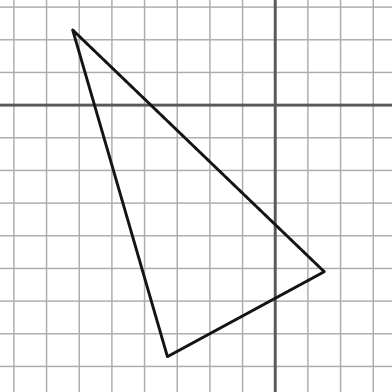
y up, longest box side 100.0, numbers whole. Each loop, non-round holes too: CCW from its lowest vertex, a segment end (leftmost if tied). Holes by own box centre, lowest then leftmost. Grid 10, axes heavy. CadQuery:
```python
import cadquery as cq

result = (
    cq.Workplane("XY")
    .moveTo(-33.0, -77.0)
    .lineTo(15.0, -51.0)
    .lineTo(-62.0, 23.0)
    .close()
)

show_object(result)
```